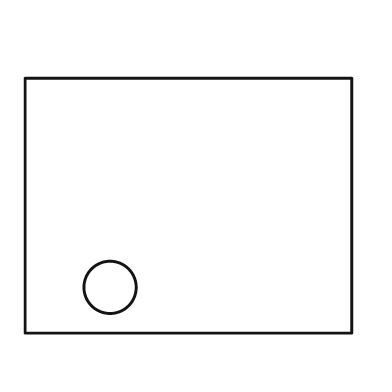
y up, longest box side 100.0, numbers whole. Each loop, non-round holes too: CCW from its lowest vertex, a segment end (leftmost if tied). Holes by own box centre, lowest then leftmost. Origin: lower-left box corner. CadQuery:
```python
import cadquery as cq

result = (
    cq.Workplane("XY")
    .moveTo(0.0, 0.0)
    .lineTo(100.0, 0.0)
    .lineTo(100.0, 78.0)
    .lineTo(0.0, 78.0)
    .close()
    .moveTo(26.0, 14.0)
    .circle(8.0)
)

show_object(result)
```